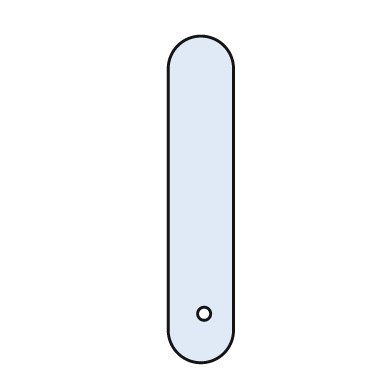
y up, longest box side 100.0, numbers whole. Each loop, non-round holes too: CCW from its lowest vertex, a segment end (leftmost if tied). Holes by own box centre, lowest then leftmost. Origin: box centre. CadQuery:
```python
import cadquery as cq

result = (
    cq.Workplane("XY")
    .moveTo(-10.0, -40.0)
    .threePointArc((0.0, -50.0), (10.0, -40.0))
    .lineTo(10.0, 40.0)
    .threePointArc((0.0, 50.0), (-10.0, 40.0))
    .close()
    .moveTo(1.0, -35.0)
    .circle(2.0)
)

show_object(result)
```